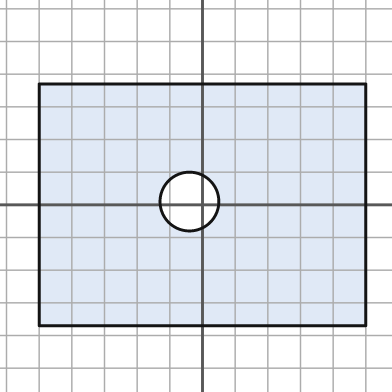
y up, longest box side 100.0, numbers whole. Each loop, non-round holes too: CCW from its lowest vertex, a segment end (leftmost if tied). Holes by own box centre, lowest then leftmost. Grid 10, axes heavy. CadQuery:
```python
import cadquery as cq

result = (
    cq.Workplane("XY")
    .moveTo(-50.0, -37.0)
    .lineTo(50.0, -37.0)
    .lineTo(50.0, 37.0)
    .lineTo(-50.0, 37.0)
    .close()
    .moveTo(-4.0, 1.0)
    .circle(9.0)
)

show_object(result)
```